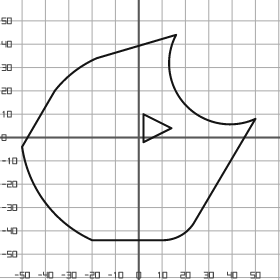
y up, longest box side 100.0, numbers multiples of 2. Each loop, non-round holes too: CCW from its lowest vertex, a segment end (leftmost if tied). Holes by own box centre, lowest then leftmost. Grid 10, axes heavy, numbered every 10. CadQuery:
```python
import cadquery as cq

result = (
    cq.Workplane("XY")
    .moveTo(-20.0, -44.0)
    .lineTo(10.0, -44.0)
    .threePointArc((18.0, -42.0), (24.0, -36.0))
    .lineTo(50.0, 8.0)
    .threePointArc((20.0, 14.0), (16.0, 44.0))
    .lineTo(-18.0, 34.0)
    .threePointArc((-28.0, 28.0), (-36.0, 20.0))
    .lineTo(-50.0, -4.0)
    .threePointArc((-40.0, -28.0), (-20.0, -44.0))
    .close()
    .moveTo(2.0, -2.0)
    .lineTo(14.0, 4.0)
    .lineTo(2.0, 10.0)
    .close()
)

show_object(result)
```